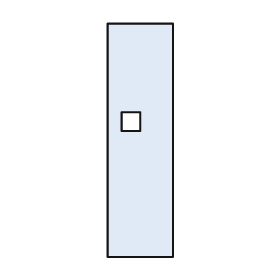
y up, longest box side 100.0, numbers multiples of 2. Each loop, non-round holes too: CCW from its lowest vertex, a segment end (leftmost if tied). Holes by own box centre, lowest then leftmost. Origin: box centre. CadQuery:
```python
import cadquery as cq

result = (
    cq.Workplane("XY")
    .moveTo(-14.0, -50.0)
    .lineTo(14.0, -50.0)
    .lineTo(14.0, 50.0)
    .lineTo(-14.0, 50.0)
    .close()
    .moveTo(-8.0, 4.0)
    .lineTo(0.0, 4.0)
    .lineTo(0.0, 12.0)
    .lineTo(-8.0, 12.0)
    .close()
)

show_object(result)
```